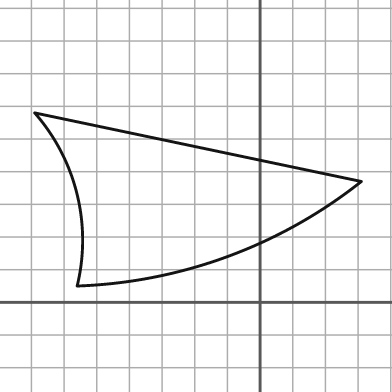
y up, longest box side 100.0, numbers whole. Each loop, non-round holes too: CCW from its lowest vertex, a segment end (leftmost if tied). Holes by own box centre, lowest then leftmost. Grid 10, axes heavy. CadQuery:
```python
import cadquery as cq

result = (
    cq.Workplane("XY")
    .moveTo(-56.0, 5.0)
    .threePointArc((-10.0, 14.0), (31.0, 37.0))
    .lineTo(-69.0, 58.0)
    .threePointArc((-56.0, 33.0), (-56.0, 5.0))
    .close()
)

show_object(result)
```